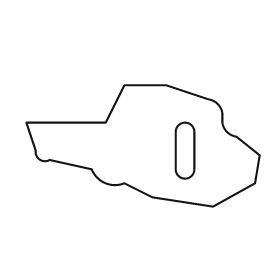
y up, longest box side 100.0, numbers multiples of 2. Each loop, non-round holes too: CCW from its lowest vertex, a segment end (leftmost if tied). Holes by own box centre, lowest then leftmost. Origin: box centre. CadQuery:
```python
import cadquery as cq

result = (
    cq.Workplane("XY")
    .moveTo(30.0, -26.0)
    .lineTo(48.0, -16.0)
    .lineTo(50.0, -4.0)
    .lineTo(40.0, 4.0)
    .threePointArc((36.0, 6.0), (34.0, 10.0))
    .lineTo(34.0, 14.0)
    .threePointArc((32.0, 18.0), (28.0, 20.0))
    .lineTo(10.0, 26.0)
    .lineTo(-8.0, 26.0)
    .lineTo(-16.0, 10.0)
    .lineTo(-50.0, 10.0)
    .lineTo(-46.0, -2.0)
    .threePointArc((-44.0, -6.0), (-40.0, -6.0))
    .lineTo(-22.0, -10.0)
    .threePointArc((-16.0, -16.0), (-8.0, -16.0))
    .lineTo(4.0, -22.0)
    .close()
    .moveTo(14.0, -10.0)
    .threePointArc((18.0, -14.0), (22.0, -10.0))
    .lineTo(22.0, 6.0)
    .threePointArc((18.0, 10.0), (14.0, 6.0))
    .close()
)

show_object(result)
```